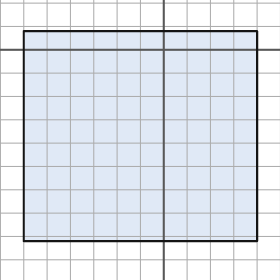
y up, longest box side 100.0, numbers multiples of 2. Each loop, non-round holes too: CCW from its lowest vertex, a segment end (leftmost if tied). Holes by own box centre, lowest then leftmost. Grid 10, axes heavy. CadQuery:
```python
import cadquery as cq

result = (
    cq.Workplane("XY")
    .moveTo(-60.0, -82.0)
    .lineTo(40.0, -82.0)
    .lineTo(40.0, 8.0)
    .lineTo(-60.0, 8.0)
    .close()
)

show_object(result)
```